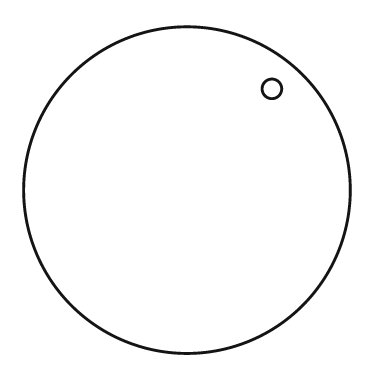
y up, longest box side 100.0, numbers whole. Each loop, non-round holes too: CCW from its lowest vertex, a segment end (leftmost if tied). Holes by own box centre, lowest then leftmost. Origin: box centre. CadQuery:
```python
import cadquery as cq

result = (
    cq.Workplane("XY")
    .moveTo(0.0, 0.0)
    .circle(50.0)
    .moveTo(26.0, 31.0)
    .circle(3.0)
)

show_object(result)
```